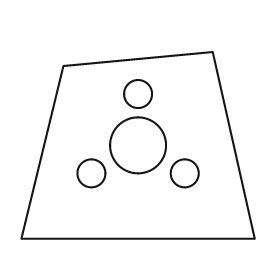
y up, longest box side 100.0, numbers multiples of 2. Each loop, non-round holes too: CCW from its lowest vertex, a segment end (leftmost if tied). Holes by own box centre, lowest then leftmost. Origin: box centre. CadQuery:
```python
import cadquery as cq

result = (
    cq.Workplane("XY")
    .moveTo(-50.0, -40.0)
    .lineTo(50.0, -40.0)
    .lineTo(32.0, 40.0)
    .lineTo(-32.0, 34.0)
    .close()
    .moveTo(-20.0, -12.0)
    .circle(6.0)
    .moveTo(20.0, -12.0)
    .circle(6.0)
    .moveTo(0.0, 0.0)
    .circle(12.0)
    .moveTo(0.0, 22.0)
    .circle(6.0)
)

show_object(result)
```